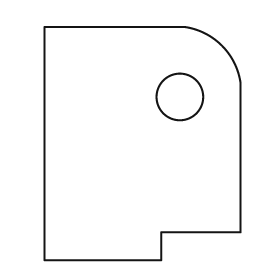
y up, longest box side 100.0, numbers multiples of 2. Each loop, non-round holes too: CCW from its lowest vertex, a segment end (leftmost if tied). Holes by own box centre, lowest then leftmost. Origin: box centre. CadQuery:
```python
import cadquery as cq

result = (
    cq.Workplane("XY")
    .moveTo(-42.0, -50.0)
    .lineTo(8.0, -50.0)
    .lineTo(8.0, -38.0)
    .lineTo(42.0, -38.0)
    .lineTo(42.0, 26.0)
    .threePointArc((34.0, 42.0), (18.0, 50.0))
    .lineTo(-42.0, 50.0)
    .close()
    .moveTo(16.0, 20.0)
    .circle(10.0)
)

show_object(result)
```